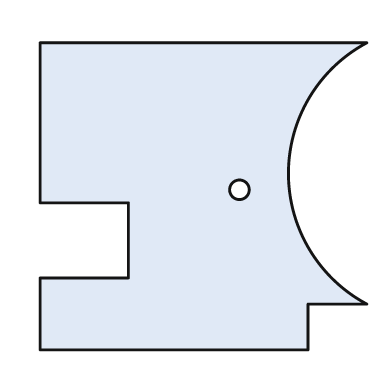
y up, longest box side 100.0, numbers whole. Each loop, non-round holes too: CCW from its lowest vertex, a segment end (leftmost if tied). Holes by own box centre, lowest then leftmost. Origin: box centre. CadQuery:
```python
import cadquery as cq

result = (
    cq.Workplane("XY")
    .moveTo(-50.0, -47.0)
    .lineTo(32.0, -47.0)
    .lineTo(32.0, -33.0)
    .lineTo(50.0, -33.0)
    .threePointArc((26.0, 7.0), (50.0, 47.0))
    .lineTo(-50.0, 47.0)
    .lineTo(-50.0, -2.0)
    .lineTo(-23.0, -2.0)
    .lineTo(-23.0, -25.0)
    .lineTo(-50.0, -25.0)
    .close()
    .moveTo(11.0, 2.0)
    .circle(3.0)
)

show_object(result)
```